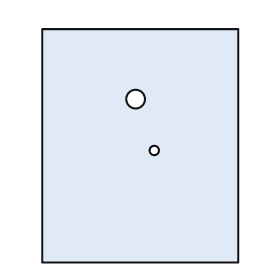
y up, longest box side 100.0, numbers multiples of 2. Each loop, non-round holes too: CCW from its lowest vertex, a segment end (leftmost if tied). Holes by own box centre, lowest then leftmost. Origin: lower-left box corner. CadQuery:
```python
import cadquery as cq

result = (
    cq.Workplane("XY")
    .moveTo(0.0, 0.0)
    .lineTo(84.0, 0.0)
    .lineTo(84.0, 100.0)
    .lineTo(0.0, 100.0)
    .close()
    .moveTo(48.0, 48.0)
    .circle(2.0)
    .moveTo(40.0, 70.0)
    .circle(4.0)
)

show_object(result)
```